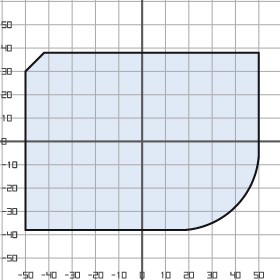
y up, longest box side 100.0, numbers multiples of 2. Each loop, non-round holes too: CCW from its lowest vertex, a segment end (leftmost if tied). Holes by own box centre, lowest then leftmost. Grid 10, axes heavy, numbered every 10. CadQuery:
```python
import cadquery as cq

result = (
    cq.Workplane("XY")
    .moveTo(-50.0, -38.0)
    .lineTo(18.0, -38.0)
    .threePointArc((40.0, -28.0), (50.0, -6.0))
    .lineTo(50.0, 38.0)
    .lineTo(-42.0, 38.0)
    .lineTo(-50.0, 30.0)
    .close()
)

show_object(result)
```